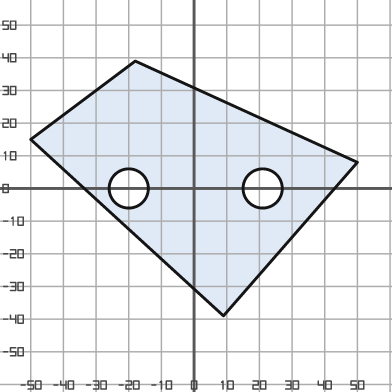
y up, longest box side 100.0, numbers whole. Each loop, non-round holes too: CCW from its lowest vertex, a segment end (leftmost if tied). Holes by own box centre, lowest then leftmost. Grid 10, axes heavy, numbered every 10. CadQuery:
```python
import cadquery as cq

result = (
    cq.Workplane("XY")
    .moveTo(9.0, -39.0)
    .lineTo(50.0, 8.0)
    .lineTo(-18.0, 39.0)
    .lineTo(-50.0, 15.0)
    .close()
    .moveTo(-20.0, 0.0)
    .circle(6.0)
    .moveTo(21.0, 0.0)
    .circle(6.0)
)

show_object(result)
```